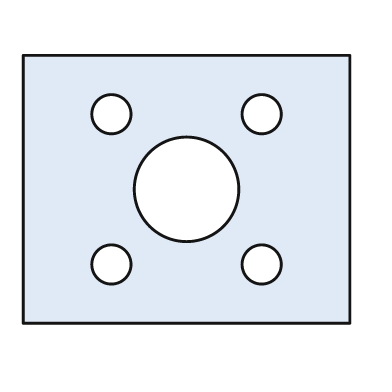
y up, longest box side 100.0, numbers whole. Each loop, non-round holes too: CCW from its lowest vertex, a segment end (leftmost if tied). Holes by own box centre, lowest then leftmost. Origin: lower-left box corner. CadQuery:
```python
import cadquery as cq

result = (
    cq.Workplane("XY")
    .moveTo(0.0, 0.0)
    .lineTo(100.0, 0.0)
    .lineTo(100.0, 82.0)
    .lineTo(0.0, 82.0)
    .close()
    .moveTo(27.0, 18.0)
    .circle(6.0)
    .moveTo(73.0, 18.0)
    .circle(6.0)
    .moveTo(50.0, 41.0)
    .circle(16.0)
    .moveTo(27.0, 64.0)
    .circle(6.0)
    .moveTo(73.0, 64.0)
    .circle(6.0)
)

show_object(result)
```